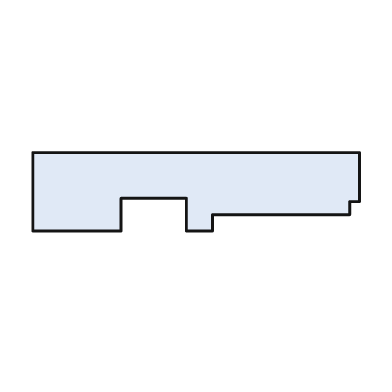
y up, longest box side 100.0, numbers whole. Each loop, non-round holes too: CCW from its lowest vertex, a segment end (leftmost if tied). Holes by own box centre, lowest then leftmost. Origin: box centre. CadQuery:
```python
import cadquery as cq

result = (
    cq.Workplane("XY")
    .moveTo(-50.0, -12.0)
    .lineTo(-23.0, -12.0)
    .lineTo(-23.0, -2.0)
    .lineTo(-3.0, -2.0)
    .lineTo(-3.0, -12.0)
    .lineTo(5.0, -12.0)
    .lineTo(5.0, -7.0)
    .lineTo(47.0, -7.0)
    .lineTo(47.0, -3.0)
    .lineTo(50.0, -3.0)
    .lineTo(50.0, 12.0)
    .lineTo(-50.0, 12.0)
    .close()
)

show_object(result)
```